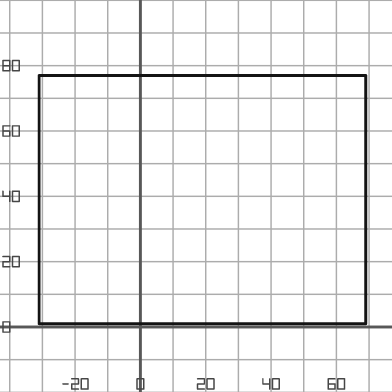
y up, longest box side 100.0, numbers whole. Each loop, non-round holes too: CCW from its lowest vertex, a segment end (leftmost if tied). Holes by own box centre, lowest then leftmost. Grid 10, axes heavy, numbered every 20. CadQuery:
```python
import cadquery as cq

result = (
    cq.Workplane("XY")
    .moveTo(-31.0, 1.0)
    .lineTo(69.0, 1.0)
    .lineTo(69.0, 77.0)
    .lineTo(-31.0, 77.0)
    .close()
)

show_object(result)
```